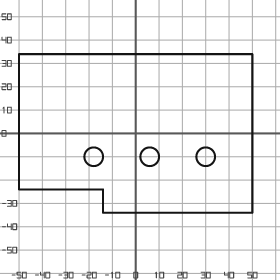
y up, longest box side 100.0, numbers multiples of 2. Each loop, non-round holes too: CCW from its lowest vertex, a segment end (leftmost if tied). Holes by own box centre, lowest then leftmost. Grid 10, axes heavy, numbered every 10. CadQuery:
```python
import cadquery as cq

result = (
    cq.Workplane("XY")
    .moveTo(-14.0, -34.0)
    .lineTo(50.0, -34.0)
    .lineTo(50.0, 34.0)
    .lineTo(-50.0, 34.0)
    .lineTo(-50.0, -24.0)
    .lineTo(-14.0, -24.0)
    .close()
    .moveTo(-18.0, -10.0)
    .circle(4.0)
    .moveTo(6.0, -10.0)
    .circle(4.0)
    .moveTo(30.0, -10.0)
    .circle(4.0)
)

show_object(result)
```